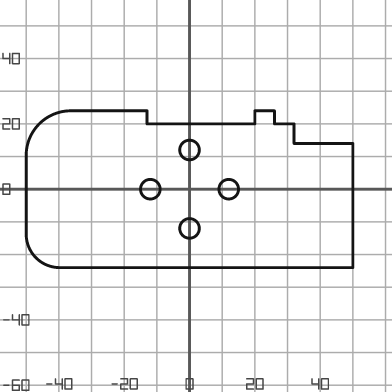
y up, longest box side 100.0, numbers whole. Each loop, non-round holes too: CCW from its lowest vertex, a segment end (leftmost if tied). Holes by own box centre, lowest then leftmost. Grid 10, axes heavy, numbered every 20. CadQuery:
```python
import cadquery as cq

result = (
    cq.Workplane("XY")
    .moveTo(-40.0, -24.0)
    .lineTo(50.0, -24.0)
    .lineTo(50.0, 14.0)
    .lineTo(32.0, 14.0)
    .lineTo(32.0, 20.0)
    .lineTo(26.0, 20.0)
    .lineTo(26.0, 24.0)
    .lineTo(20.0, 24.0)
    .lineTo(20.0, 20.0)
    .lineTo(-13.0, 20.0)
    .lineTo(-13.0, 24.0)
    .lineTo(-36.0, 24.0)
    .threePointArc((-46.0, 20.0), (-50.0, 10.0))
    .lineTo(-50.0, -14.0)
    .threePointArc((-47.0, -21.0), (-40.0, -24.0))
    .close()
    .moveTo(0.0, -12.0)
    .circle(3.0)
    .moveTo(-12.0, 0.0)
    .circle(3.0)
    .moveTo(12.0, 0.0)
    .circle(3.0)
    .moveTo(0.0, 12.0)
    .circle(3.0)
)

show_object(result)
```